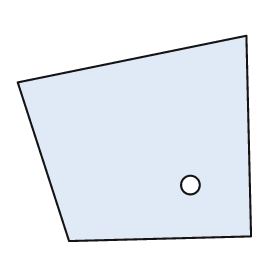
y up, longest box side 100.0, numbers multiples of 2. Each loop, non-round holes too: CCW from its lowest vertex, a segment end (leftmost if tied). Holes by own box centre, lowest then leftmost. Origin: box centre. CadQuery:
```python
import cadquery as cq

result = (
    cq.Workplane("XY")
    .moveTo(-28.0, -44.0)
    .lineTo(50.0, -42.0)
    .lineTo(48.0, 44.0)
    .lineTo(-50.0, 24.0)
    .close()
    .moveTo(24.0, -20.0)
    .circle(4.0)
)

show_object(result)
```